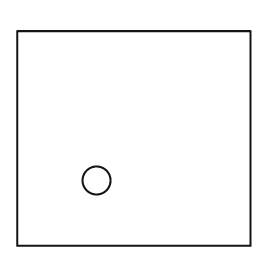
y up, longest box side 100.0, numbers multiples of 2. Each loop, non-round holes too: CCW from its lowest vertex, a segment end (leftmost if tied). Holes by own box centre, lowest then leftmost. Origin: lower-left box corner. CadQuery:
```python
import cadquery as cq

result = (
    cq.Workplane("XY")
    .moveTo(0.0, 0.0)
    .lineTo(100.0, 0.0)
    .lineTo(100.0, 92.0)
    .lineTo(0.0, 92.0)
    .close()
    .moveTo(34.0, 28.0)
    .circle(6.0)
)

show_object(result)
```